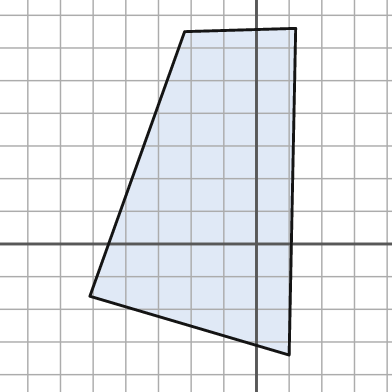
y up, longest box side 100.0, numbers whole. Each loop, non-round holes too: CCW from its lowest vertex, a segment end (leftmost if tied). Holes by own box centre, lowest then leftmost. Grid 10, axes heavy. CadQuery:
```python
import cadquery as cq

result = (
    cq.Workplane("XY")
    .moveTo(10.0, -34.0)
    .lineTo(12.0, 66.0)
    .lineTo(-22.0, 65.0)
    .lineTo(-51.0, -16.0)
    .close()
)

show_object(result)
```